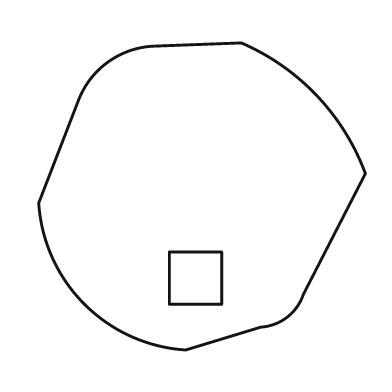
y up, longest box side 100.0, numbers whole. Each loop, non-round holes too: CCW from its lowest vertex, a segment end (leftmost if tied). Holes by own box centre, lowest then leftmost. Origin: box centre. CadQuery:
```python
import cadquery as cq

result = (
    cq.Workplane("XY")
    .moveTo(-5.0, -47.0)
    .lineTo(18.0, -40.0)
    .threePointArc((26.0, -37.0), (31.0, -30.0))
    .lineTo(50.0, 7.0)
    .threePointArc((35.0, 31.0), (12.0, 47.0))
    .lineTo(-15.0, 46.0)
    .threePointArc((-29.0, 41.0), (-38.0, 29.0))
    .lineTo(-50.0, -2.0)
    .threePointArc((-36.0, -33.0), (-5.0, -47.0))
    .close()
    .moveTo(-10.0, -33.0)
    .lineTo(6.0, -33.0)
    .lineTo(6.0, -17.0)
    .lineTo(-10.0, -17.0)
    .close()
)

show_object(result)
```